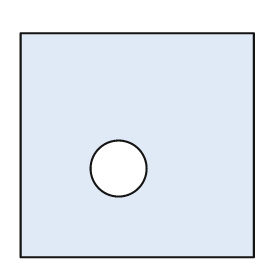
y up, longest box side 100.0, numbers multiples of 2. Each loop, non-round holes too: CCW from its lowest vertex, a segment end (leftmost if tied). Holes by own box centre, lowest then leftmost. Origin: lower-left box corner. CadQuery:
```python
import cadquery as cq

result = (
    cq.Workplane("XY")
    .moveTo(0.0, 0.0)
    .lineTo(100.0, 0.0)
    .lineTo(100.0, 96.0)
    .lineTo(0.0, 96.0)
    .close()
    .moveTo(42.0, 38.0)
    .circle(12.0)
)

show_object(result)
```